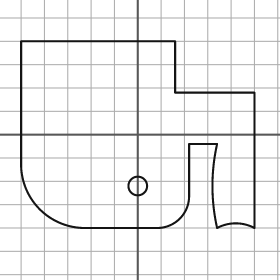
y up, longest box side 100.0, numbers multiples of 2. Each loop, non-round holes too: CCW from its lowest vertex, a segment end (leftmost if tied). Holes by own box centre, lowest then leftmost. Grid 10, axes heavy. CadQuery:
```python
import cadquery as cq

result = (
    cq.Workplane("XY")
    .moveTo(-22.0, -40.0)
    .lineTo(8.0, -40.0)
    .threePointArc((18.0, -36.0), (22.0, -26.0))
    .lineTo(22.0, -4.0)
    .lineTo(34.0, -4.0)
    .threePointArc((32.0, -22.0), (34.0, -40.0))
    .threePointArc((42.0, -38.0), (50.0, -40.0))
    .lineTo(50.0, 18.0)
    .lineTo(16.0, 18.0)
    .lineTo(16.0, 40.0)
    .lineTo(-50.0, 40.0)
    .lineTo(-50.0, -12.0)
    .threePointArc((-42.0, -32.0), (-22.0, -40.0))
    .close()
    .moveTo(0.0, -22.0)
    .circle(4.0)
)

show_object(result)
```